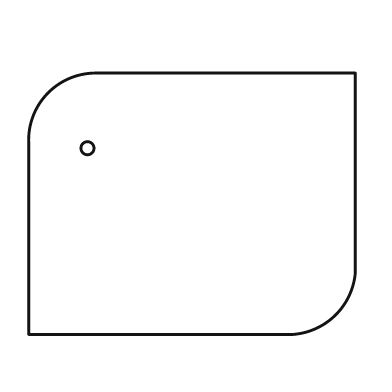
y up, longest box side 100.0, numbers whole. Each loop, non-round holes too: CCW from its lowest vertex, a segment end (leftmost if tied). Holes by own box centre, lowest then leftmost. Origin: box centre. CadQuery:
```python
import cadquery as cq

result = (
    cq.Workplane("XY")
    .moveTo(-50.0, -40.0)
    .lineTo(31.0, -40.0)
    .threePointArc((44.0, -34.0), (50.0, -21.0))
    .lineTo(50.0, 40.0)
    .lineTo(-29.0, 40.0)
    .threePointArc((-44.0, 34.0), (-50.0, 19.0))
    .close()
    .moveTo(-32.0, 17.0)
    .circle(2.0)
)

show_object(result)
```